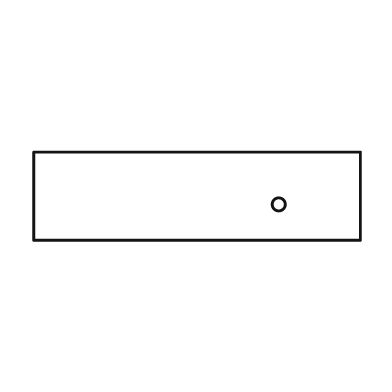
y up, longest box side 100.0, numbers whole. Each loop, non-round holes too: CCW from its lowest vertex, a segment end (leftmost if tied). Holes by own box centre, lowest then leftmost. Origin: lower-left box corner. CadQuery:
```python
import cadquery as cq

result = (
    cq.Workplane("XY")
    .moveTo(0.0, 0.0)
    .lineTo(100.0, 0.0)
    .lineTo(100.0, 27.0)
    .lineTo(0.0, 27.0)
    .close()
    .moveTo(75.0, 11.0)
    .circle(2.0)
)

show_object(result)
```